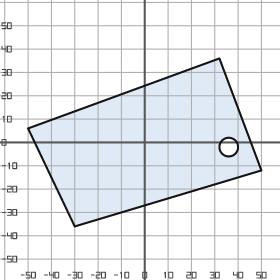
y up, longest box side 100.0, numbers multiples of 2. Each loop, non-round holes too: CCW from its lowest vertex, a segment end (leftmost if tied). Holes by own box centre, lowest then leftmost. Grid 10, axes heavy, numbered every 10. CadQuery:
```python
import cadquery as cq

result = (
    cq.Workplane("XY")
    .moveTo(-30.0, -36.0)
    .lineTo(50.0, -12.0)
    .lineTo(32.0, 36.0)
    .lineTo(-50.0, 6.0)
    .close()
    .moveTo(36.0, -2.0)
    .circle(4.0)
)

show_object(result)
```